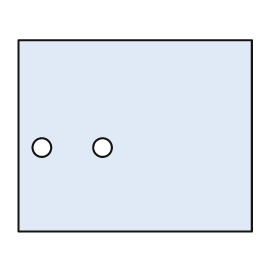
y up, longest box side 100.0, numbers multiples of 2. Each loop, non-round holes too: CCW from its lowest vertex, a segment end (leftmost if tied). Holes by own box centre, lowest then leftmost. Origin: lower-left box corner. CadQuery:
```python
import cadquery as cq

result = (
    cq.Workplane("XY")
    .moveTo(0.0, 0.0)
    .lineTo(100.0, 0.0)
    .lineTo(100.0, 82.0)
    .lineTo(0.0, 82.0)
    .close()
    .moveTo(10.0, 36.0)
    .circle(4.0)
    .moveTo(36.0, 36.0)
    .circle(4.0)
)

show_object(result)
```